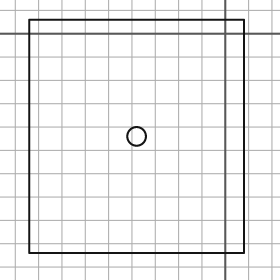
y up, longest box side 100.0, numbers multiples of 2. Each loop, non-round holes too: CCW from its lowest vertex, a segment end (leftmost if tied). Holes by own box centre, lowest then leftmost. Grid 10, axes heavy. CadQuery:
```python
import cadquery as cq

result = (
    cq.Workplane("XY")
    .moveTo(-84.0, -94.0)
    .lineTo(8.0, -94.0)
    .lineTo(8.0, 6.0)
    .lineTo(-84.0, 6.0)
    .close()
    .moveTo(-38.0, -44.0)
    .circle(4.0)
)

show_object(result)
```